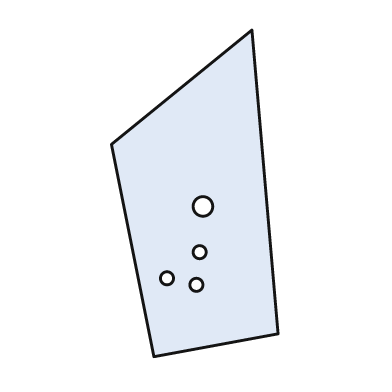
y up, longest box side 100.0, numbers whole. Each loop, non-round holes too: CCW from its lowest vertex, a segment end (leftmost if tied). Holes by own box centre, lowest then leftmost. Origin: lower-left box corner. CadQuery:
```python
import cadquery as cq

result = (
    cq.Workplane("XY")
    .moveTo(13.0, 0.0)
    .lineTo(51.0, 7.0)
    .lineTo(43.0, 100.0)
    .lineTo(0.0, 65.0)
    .close()
    .moveTo(26.0, 22.0)
    .circle(2.0)
    .moveTo(17.0, 24.0)
    .circle(2.0)
    .moveTo(27.0, 32.0)
    .circle(2.0)
    .moveTo(28.0, 46.0)
    .circle(3.0)
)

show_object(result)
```